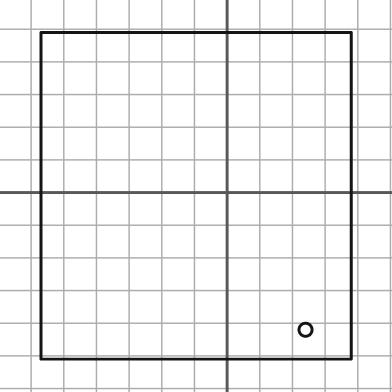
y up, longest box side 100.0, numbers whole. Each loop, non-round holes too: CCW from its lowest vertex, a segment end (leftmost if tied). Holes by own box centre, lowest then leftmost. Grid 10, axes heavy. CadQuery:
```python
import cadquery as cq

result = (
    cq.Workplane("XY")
    .moveTo(-57.0, -51.0)
    .lineTo(38.0, -51.0)
    .lineTo(38.0, 49.0)
    .lineTo(-57.0, 49.0)
    .close()
    .moveTo(24.0, -42.0)
    .circle(2.0)
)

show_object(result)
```